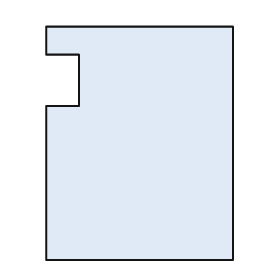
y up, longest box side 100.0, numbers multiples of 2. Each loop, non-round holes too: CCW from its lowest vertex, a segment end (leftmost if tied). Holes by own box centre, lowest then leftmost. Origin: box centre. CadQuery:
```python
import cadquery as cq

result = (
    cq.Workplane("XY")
    .moveTo(-40.0, -50.0)
    .lineTo(40.0, -50.0)
    .lineTo(40.0, 50.0)
    .lineTo(-40.0, 50.0)
    .lineTo(-40.0, 38.0)
    .lineTo(-26.0, 38.0)
    .lineTo(-26.0, 16.0)
    .lineTo(-40.0, 16.0)
    .close()
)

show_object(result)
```